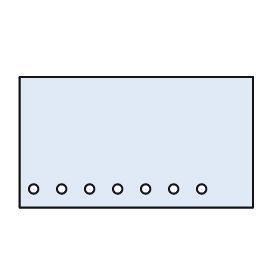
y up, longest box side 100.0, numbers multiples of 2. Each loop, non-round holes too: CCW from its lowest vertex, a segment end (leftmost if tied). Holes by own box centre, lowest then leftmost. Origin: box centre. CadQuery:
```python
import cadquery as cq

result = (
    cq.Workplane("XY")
    .moveTo(-50.0, -28.0)
    .lineTo(50.0, -28.0)
    .lineTo(50.0, 28.0)
    .lineTo(-50.0, 28.0)
    .close()
    .moveTo(-44.0, -20.0)
    .circle(2.0)
    .moveTo(-32.0, -20.0)
    .circle(2.0)
    .moveTo(-20.0, -20.0)
    .circle(2.0)
    .moveTo(-8.0, -20.0)
    .circle(2.0)
    .moveTo(4.0, -20.0)
    .circle(2.0)
    .moveTo(16.0, -20.0)
    .circle(2.0)
    .moveTo(28.0, -20.0)
    .circle(2.0)
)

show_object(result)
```